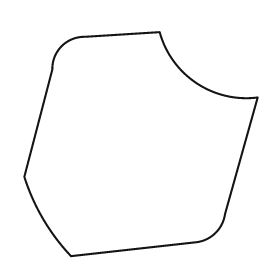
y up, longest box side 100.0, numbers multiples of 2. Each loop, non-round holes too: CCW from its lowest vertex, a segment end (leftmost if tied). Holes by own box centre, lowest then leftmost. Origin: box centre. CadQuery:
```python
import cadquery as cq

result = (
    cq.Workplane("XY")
    .moveTo(-30.0, -48.0)
    .lineTo(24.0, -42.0)
    .threePointArc((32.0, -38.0), (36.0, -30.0))
    .lineTo(50.0, 20.0)
    .threePointArc((24.0, 26.0), (8.0, 48.0))
    .lineTo(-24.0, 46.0)
    .threePointArc((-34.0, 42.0), (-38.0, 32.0))
    .lineTo(-50.0, -14.0)
    .threePointArc((-42.0, -32.0), (-30.0, -48.0))
    .close()
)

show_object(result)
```